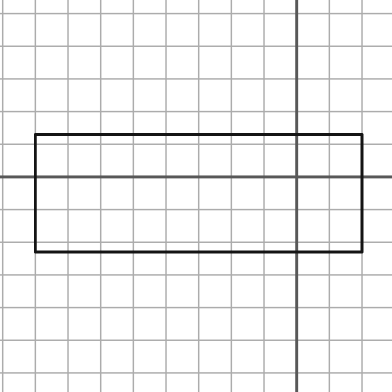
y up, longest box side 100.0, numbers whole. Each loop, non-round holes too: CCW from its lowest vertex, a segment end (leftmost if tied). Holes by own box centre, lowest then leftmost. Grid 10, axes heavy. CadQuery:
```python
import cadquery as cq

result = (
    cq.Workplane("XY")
    .moveTo(-80.0, -23.0)
    .lineTo(20.0, -23.0)
    .lineTo(20.0, 13.0)
    .lineTo(-80.0, 13.0)
    .close()
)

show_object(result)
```